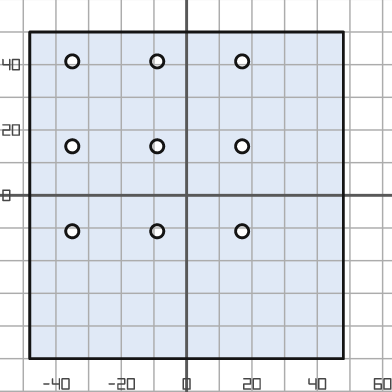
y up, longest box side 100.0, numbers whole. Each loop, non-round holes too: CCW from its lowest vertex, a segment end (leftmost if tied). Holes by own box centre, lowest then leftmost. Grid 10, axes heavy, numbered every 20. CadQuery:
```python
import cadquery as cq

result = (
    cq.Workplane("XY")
    .moveTo(-48.0, -50.0)
    .lineTo(48.0, -50.0)
    .lineTo(48.0, 50.0)
    .lineTo(-48.0, 50.0)
    .close()
    .moveTo(-35.0, -11.0)
    .circle(2.0)
    .moveTo(-9.0, -11.0)
    .circle(2.0)
    .moveTo(17.0, -11.0)
    .circle(2.0)
    .moveTo(-35.0, 15.0)
    .circle(2.0)
    .moveTo(-9.0, 15.0)
    .circle(2.0)
    .moveTo(17.0, 15.0)
    .circle(2.0)
    .moveTo(-35.0, 41.0)
    .circle(2.0)
    .moveTo(-9.0, 41.0)
    .circle(2.0)
    .moveTo(17.0, 41.0)
    .circle(2.0)
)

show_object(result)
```